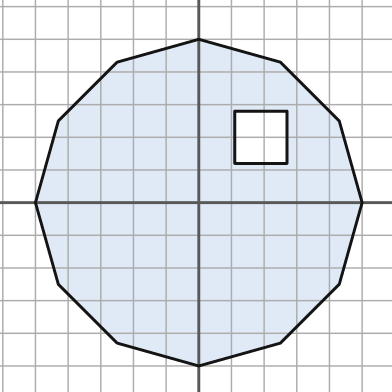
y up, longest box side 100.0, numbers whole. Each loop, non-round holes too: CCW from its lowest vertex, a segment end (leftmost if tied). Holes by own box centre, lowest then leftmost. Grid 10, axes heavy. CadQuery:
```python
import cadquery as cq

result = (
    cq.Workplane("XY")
    .moveTo(0.0, -50.0)
    .lineTo(25.0, -43.0)
    .lineTo(43.0, -25.0)
    .lineTo(50.0, 0.0)
    .lineTo(43.0, 25.0)
    .lineTo(25.0, 43.0)
    .lineTo(0.0, 50.0)
    .lineTo(-25.0, 43.0)
    .lineTo(-43.0, 25.0)
    .lineTo(-50.0, 0.0)
    .lineTo(-43.0, -25.0)
    .lineTo(-25.0, -43.0)
    .close()
    .moveTo(11.0, 12.0)
    .lineTo(27.0, 12.0)
    .lineTo(27.0, 28.0)
    .lineTo(11.0, 28.0)
    .close()
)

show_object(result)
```